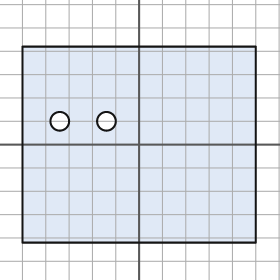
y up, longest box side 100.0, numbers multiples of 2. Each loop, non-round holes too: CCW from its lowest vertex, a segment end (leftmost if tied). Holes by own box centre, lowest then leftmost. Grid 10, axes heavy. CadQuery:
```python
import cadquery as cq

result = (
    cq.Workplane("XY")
    .moveTo(-50.0, -42.0)
    .lineTo(50.0, -42.0)
    .lineTo(50.0, 42.0)
    .lineTo(-50.0, 42.0)
    .close()
    .moveTo(-34.0, 10.0)
    .circle(4.0)
    .moveTo(-14.0, 10.0)
    .circle(4.0)
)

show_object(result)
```